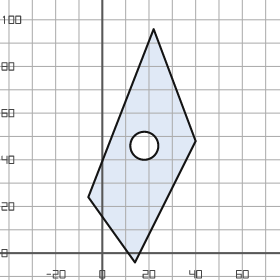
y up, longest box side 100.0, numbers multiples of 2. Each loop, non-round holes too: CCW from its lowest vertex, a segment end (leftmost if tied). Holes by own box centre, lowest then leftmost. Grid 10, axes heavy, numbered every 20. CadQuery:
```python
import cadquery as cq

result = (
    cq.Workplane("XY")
    .moveTo(14.0, -4.0)
    .lineTo(40.0, 48.0)
    .lineTo(22.0, 96.0)
    .lineTo(-6.0, 24.0)
    .close()
    .moveTo(18.0, 46.0)
    .circle(6.0)
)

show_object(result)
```